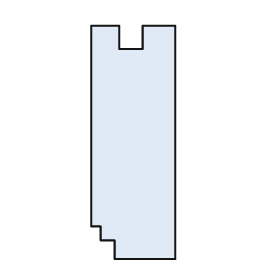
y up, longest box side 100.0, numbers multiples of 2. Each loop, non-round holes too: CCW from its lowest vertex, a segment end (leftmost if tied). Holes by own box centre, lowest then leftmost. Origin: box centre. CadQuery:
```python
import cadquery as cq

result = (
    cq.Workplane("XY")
    .moveTo(-8.0, -50.0)
    .lineTo(18.0, -50.0)
    .lineTo(18.0, 50.0)
    .lineTo(4.0, 50.0)
    .lineTo(4.0, 40.0)
    .lineTo(-6.0, 40.0)
    .lineTo(-6.0, 50.0)
    .lineTo(-18.0, 50.0)
    .lineTo(-18.0, -36.0)
    .lineTo(-14.0, -36.0)
    .lineTo(-14.0, -42.0)
    .lineTo(-8.0, -42.0)
    .close()
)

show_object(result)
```